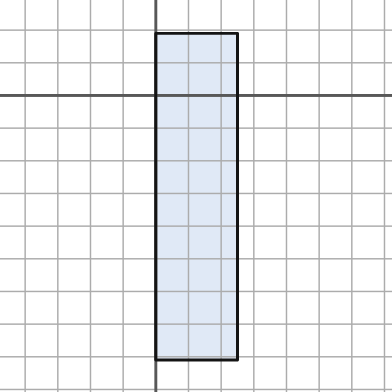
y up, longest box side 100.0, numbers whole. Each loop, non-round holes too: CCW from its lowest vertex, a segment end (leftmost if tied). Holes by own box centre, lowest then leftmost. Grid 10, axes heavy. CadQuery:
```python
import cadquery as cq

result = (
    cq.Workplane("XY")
    .moveTo(0.0, -81.0)
    .lineTo(25.0, -81.0)
    .lineTo(25.0, 19.0)
    .lineTo(0.0, 19.0)
    .close()
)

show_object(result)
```